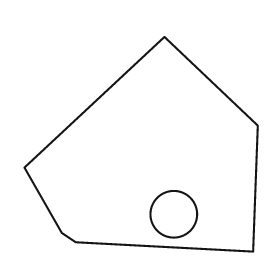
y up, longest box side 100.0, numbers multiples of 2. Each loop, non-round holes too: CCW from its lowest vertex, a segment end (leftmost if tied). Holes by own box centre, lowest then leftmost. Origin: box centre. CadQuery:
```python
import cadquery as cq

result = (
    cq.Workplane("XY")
    .moveTo(48.0, -46.0)
    .lineTo(50.0, 8.0)
    .lineTo(10.0, 46.0)
    .lineTo(-50.0, -10.0)
    .lineTo(-34.0, -38.0)
    .lineTo(-28.0, -42.0)
    .close()
    .moveTo(14.0, -30.0)
    .circle(10.0)
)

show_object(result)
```